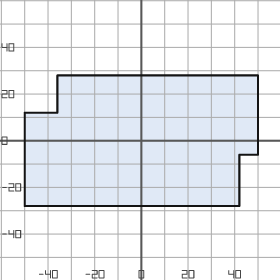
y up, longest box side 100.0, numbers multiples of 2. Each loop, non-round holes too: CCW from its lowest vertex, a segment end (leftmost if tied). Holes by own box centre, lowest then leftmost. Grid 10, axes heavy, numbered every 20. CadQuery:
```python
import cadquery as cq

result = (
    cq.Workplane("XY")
    .moveTo(-50.0, -28.0)
    .lineTo(42.0, -28.0)
    .lineTo(42.0, -6.0)
    .lineTo(50.0, -6.0)
    .lineTo(50.0, 28.0)
    .lineTo(-36.0, 28.0)
    .lineTo(-36.0, 12.0)
    .lineTo(-50.0, 12.0)
    .close()
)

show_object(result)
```